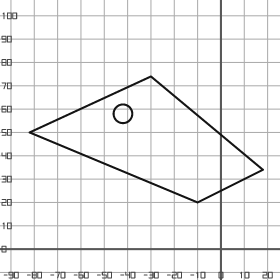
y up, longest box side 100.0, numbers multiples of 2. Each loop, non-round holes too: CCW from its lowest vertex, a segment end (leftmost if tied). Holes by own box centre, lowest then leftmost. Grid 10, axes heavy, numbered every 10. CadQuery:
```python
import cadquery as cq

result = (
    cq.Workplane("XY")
    .moveTo(-10.0, 20.0)
    .lineTo(18.0, 34.0)
    .lineTo(-30.0, 74.0)
    .lineTo(-82.0, 50.0)
    .close()
    .moveTo(-42.0, 58.0)
    .circle(4.0)
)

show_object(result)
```